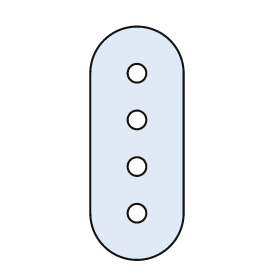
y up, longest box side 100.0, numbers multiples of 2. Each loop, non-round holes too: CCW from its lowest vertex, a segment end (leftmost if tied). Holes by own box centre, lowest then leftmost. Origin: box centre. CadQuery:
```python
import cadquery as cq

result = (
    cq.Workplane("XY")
    .moveTo(-20.0, -30.0)
    .threePointArc((0.0, -50.0), (20.0, -30.0))
    .lineTo(20.0, 30.0)
    .threePointArc((0.0, 50.0), (-20.0, 30.0))
    .close()
    .moveTo(0.0, -30.0)
    .circle(4.0)
    .moveTo(0.0, -10.0)
    .circle(4.0)
    .moveTo(0.0, 10.0)
    .circle(4.0)
    .moveTo(0.0, 30.0)
    .circle(4.0)
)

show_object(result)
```